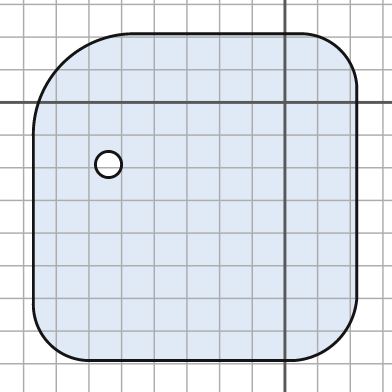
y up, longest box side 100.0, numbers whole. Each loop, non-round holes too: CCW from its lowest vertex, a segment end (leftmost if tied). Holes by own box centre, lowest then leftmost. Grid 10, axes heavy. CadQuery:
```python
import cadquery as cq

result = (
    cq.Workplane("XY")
    .moveTo(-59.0, -79.0)
    .lineTo(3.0, -79.0)
    .threePointArc((16.0, -73.0), (22.0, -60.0))
    .lineTo(22.0, 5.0)
    .threePointArc((17.0, 16.0), (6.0, 21.0))
    .lineTo(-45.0, 21.0)
    .threePointArc((-68.0, 12.0), (-77.0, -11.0))
    .lineTo(-77.0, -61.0)
    .threePointArc((-72.0, -74.0), (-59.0, -79.0))
    .close()
    .moveTo(-54.0, -19.0)
    .circle(4.0)
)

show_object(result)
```